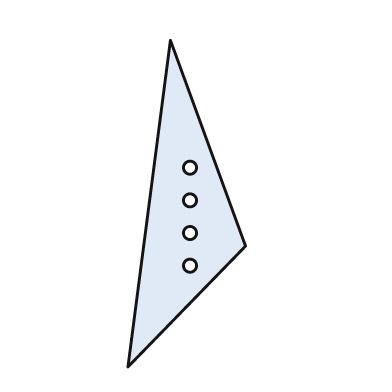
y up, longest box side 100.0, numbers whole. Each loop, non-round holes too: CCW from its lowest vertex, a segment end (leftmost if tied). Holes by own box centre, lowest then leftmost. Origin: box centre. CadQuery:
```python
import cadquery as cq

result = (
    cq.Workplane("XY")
    .moveTo(-18.0, -50.0)
    .lineTo(18.0, -13.0)
    .lineTo(-5.0, 50.0)
    .close()
    .moveTo(1.0, -19.0)
    .circle(2.0)
    .moveTo(1.0, -9.0)
    .circle(2.0)
    .moveTo(1.0, 1.0)
    .circle(2.0)
    .moveTo(1.0, 11.0)
    .circle(2.0)
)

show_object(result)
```